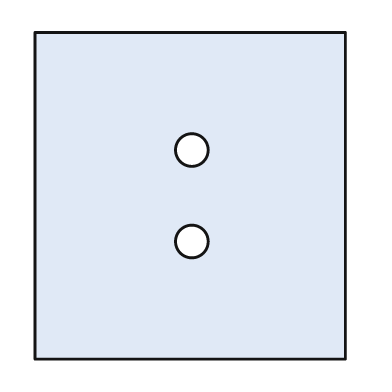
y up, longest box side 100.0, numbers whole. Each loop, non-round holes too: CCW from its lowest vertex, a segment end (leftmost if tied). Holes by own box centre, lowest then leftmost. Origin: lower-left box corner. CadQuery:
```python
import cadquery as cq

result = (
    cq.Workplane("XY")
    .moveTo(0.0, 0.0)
    .lineTo(95.0, 0.0)
    .lineTo(95.0, 100.0)
    .lineTo(0.0, 100.0)
    .close()
    .moveTo(48.0, 36.0)
    .circle(5.0)
    .moveTo(48.0, 64.0)
    .circle(5.0)
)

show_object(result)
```